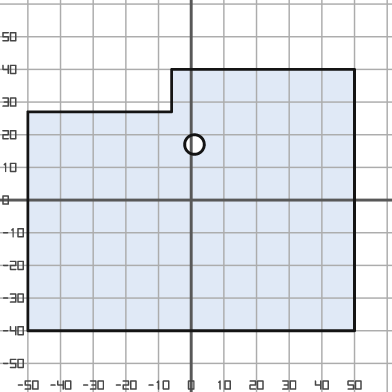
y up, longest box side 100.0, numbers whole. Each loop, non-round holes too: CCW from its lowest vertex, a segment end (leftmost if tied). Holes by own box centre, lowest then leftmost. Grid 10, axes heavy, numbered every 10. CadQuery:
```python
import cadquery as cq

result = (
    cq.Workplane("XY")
    .moveTo(-50.0, -40.0)
    .lineTo(50.0, -40.0)
    .lineTo(50.0, 40.0)
    .lineTo(-6.0, 40.0)
    .lineTo(-6.0, 27.0)
    .lineTo(-50.0, 27.0)
    .close()
    .moveTo(1.0, 17.0)
    .circle(3.0)
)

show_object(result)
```